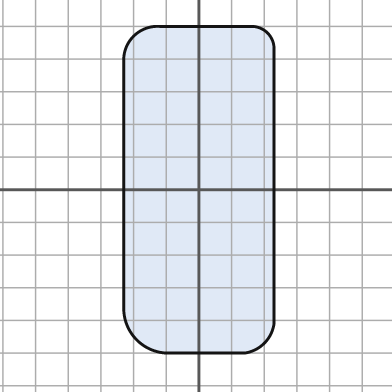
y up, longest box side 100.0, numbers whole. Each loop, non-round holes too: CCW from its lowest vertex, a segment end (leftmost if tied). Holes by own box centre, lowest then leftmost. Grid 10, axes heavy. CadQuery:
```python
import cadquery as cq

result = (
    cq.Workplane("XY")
    .moveTo(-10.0, -50.0)
    .lineTo(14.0, -50.0)
    .threePointArc((20.0, -47.0), (23.0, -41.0))
    .lineTo(23.0, 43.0)
    .threePointArc((21.0, 48.0), (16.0, 50.0))
    .lineTo(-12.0, 50.0)
    .threePointArc((-20.0, 47.0), (-23.0, 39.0))
    .lineTo(-23.0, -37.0)
    .threePointArc((-19.0, -46.0), (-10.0, -50.0))
    .close()
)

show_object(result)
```